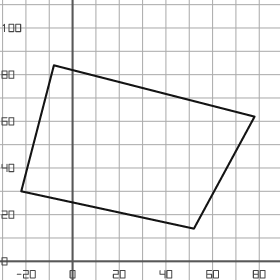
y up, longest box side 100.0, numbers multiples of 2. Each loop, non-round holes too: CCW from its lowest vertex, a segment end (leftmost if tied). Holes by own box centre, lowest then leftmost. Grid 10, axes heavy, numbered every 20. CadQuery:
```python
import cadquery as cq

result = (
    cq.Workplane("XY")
    .moveTo(52.0, 14.0)
    .lineTo(78.0, 62.0)
    .lineTo(-8.0, 84.0)
    .lineTo(-22.0, 30.0)
    .close()
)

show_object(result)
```